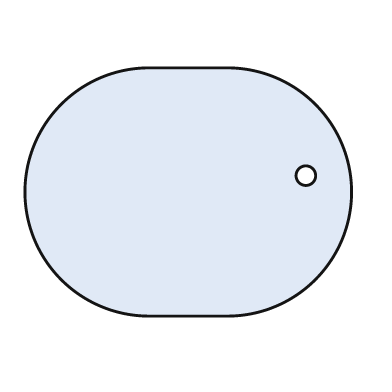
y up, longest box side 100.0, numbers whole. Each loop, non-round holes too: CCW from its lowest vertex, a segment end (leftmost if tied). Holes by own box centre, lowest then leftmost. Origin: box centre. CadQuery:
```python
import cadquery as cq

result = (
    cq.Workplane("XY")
    .moveTo(-12.0, -38.0)
    .lineTo(12.0, -38.0)
    .threePointArc((50.0, 0.0), (12.0, 38.0))
    .lineTo(-12.0, 38.0)
    .threePointArc((-50.0, 0.0), (-12.0, -38.0))
    .close()
    .moveTo(36.0, 5.0)
    .circle(3.0)
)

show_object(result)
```